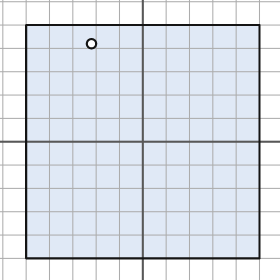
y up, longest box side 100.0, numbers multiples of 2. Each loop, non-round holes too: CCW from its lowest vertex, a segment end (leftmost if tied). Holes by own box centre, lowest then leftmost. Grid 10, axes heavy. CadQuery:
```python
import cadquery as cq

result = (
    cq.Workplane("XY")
    .moveTo(-50.0, -50.0)
    .lineTo(50.0, -50.0)
    .lineTo(50.0, 50.0)
    .lineTo(-50.0, 50.0)
    .close()
    .moveTo(-22.0, 42.0)
    .circle(2.0)
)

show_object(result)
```